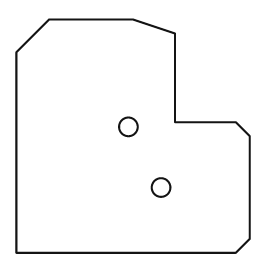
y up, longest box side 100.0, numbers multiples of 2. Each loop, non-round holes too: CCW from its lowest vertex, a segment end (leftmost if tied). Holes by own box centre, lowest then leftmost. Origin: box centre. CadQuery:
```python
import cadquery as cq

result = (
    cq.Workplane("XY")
    .moveTo(-50.0, -50.0)
    .lineTo(44.0, -50.0)
    .lineTo(50.0, -44.0)
    .lineTo(50.0, 0.0)
    .lineTo(44.0, 6.0)
    .lineTo(18.0, 6.0)
    .lineTo(18.0, 44.0)
    .lineTo(0.0, 50.0)
    .lineTo(-36.0, 50.0)
    .lineTo(-50.0, 36.0)
    .close()
    .moveTo(12.0, -22.0)
    .circle(4.0)
    .moveTo(-2.0, 4.0)
    .circle(4.0)
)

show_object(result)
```